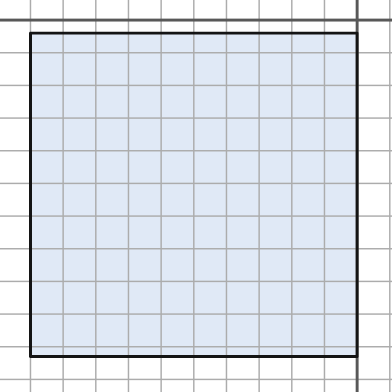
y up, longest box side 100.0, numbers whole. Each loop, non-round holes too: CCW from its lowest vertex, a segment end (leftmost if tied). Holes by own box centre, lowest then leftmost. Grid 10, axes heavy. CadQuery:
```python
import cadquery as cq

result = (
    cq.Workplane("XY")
    .moveTo(-100.0, -103.0)
    .lineTo(0.0, -103.0)
    .lineTo(0.0, -4.0)
    .lineTo(-100.0, -4.0)
    .close()
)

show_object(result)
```